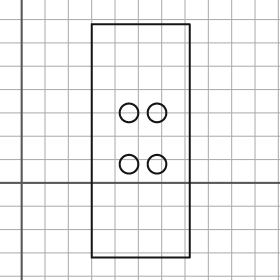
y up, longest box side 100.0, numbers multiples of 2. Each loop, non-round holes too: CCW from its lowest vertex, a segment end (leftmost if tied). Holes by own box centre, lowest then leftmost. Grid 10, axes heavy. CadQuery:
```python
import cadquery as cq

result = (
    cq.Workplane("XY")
    .moveTo(30.0, -32.0)
    .lineTo(72.0, -32.0)
    .lineTo(72.0, 68.0)
    .lineTo(30.0, 68.0)
    .close()
    .moveTo(46.0, 8.0)
    .circle(4.0)
    .moveTo(58.0, 8.0)
    .circle(4.0)
    .moveTo(46.0, 30.0)
    .circle(4.0)
    .moveTo(58.0, 30.0)
    .circle(4.0)
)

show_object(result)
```